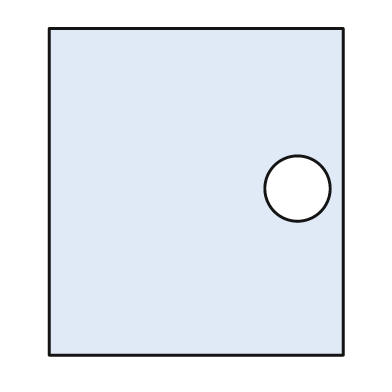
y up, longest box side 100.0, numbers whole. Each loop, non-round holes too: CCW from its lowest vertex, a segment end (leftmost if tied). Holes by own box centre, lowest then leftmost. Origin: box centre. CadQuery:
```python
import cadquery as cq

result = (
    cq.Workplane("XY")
    .moveTo(-45.0, -50.0)
    .lineTo(45.0, -50.0)
    .lineTo(45.0, 50.0)
    .lineTo(-45.0, 50.0)
    .close()
    .moveTo(31.0, 1.0)
    .circle(10.0)
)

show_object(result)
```